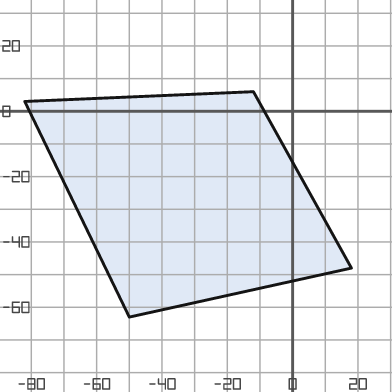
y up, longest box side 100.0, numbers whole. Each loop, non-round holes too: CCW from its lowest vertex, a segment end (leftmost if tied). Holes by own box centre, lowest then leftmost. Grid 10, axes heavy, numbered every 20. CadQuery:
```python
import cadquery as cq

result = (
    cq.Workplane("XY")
    .moveTo(-50.0, -63.0)
    .lineTo(18.0, -48.0)
    .lineTo(-12.0, 6.0)
    .lineTo(-82.0, 3.0)
    .close()
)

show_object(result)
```